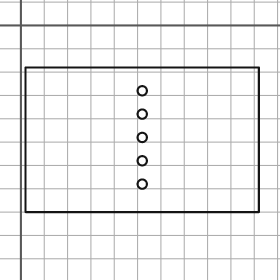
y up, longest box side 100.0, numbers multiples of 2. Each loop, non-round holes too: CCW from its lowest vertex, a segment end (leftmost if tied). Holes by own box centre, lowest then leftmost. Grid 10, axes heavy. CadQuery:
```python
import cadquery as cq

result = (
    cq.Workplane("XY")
    .moveTo(2.0, -80.0)
    .lineTo(102.0, -80.0)
    .lineTo(102.0, -18.0)
    .lineTo(2.0, -18.0)
    .close()
    .moveTo(52.0, -68.0)
    .circle(2.0)
    .moveTo(52.0, -58.0)
    .circle(2.0)
    .moveTo(52.0, -48.0)
    .circle(2.0)
    .moveTo(52.0, -38.0)
    .circle(2.0)
    .moveTo(52.0, -28.0)
    .circle(2.0)
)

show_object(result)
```